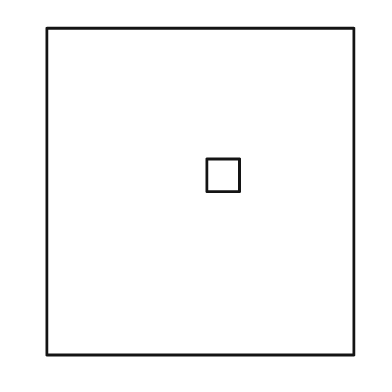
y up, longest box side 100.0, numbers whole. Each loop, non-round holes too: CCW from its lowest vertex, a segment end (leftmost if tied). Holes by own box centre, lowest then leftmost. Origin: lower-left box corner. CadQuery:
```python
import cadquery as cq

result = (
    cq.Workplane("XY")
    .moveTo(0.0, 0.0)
    .lineTo(94.0, 0.0)
    .lineTo(94.0, 100.0)
    .lineTo(0.0, 100.0)
    .close()
    .moveTo(49.0, 50.0)
    .lineTo(59.0, 50.0)
    .lineTo(59.0, 60.0)
    .lineTo(49.0, 60.0)
    .close()
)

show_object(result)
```